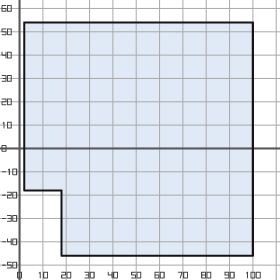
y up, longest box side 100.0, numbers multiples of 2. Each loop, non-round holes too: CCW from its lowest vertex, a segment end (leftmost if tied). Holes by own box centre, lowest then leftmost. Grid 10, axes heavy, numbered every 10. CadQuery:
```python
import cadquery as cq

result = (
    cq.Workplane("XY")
    .moveTo(18.0, -46.0)
    .lineTo(100.0, -46.0)
    .lineTo(100.0, 54.0)
    .lineTo(2.0, 54.0)
    .lineTo(2.0, -18.0)
    .lineTo(18.0, -18.0)
    .close()
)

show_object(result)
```